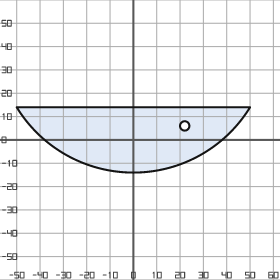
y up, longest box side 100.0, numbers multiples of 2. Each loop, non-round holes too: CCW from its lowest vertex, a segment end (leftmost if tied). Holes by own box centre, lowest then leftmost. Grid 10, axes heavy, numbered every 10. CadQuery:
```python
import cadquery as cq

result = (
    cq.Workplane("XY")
    .moveTo(-50.0, 14.0)
    .threePointArc((0.0, -14.0), (50.0, 14.0))
    .close()
    .moveTo(22.0, 6.0)
    .circle(2.0)
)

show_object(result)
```